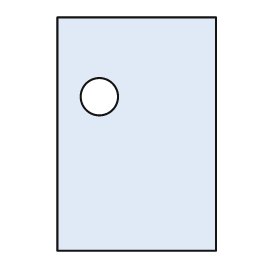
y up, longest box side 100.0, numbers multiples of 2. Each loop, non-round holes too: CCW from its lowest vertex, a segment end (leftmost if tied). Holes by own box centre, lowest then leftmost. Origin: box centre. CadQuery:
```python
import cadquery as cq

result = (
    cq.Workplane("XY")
    .moveTo(-34.0, -50.0)
    .lineTo(34.0, -50.0)
    .lineTo(34.0, 50.0)
    .lineTo(-34.0, 50.0)
    .close()
    .moveTo(-16.0, 16.0)
    .circle(8.0)
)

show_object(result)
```